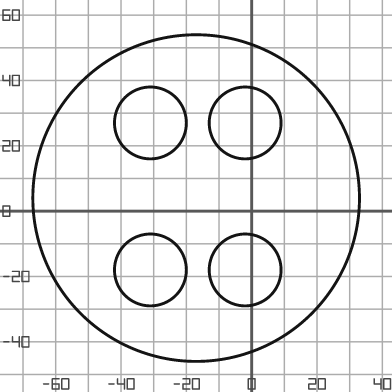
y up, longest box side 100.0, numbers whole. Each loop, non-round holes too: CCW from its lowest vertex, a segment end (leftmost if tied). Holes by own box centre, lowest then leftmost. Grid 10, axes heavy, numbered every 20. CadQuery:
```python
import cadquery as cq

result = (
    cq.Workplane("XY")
    .moveTo(-17.0, 4.0)
    .circle(50.0)
    .moveTo(-31.0, -18.0)
    .circle(11.0)
    .moveTo(-2.0, -18.0)
    .circle(11.0)
    .moveTo(-31.0, 27.0)
    .circle(11.0)
    .moveTo(-2.0, 27.0)
    .circle(11.0)
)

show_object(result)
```